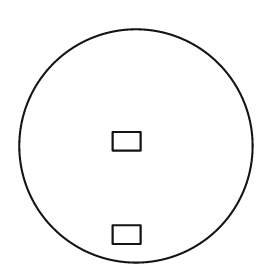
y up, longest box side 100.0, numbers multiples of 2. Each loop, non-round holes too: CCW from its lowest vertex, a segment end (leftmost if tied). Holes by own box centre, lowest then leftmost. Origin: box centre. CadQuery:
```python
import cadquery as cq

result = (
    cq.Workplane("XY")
    .moveTo(0.0, 0.0)
    .circle(50.0)
    .moveTo(-10.0, -42.0)
    .lineTo(2.0, -42.0)
    .lineTo(2.0, -34.0)
    .lineTo(-10.0, -34.0)
    .close()
    .moveTo(-10.0, -2.0)
    .lineTo(2.0, -2.0)
    .lineTo(2.0, 6.0)
    .lineTo(-10.0, 6.0)
    .close()
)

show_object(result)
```